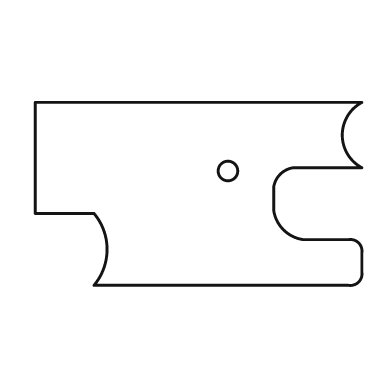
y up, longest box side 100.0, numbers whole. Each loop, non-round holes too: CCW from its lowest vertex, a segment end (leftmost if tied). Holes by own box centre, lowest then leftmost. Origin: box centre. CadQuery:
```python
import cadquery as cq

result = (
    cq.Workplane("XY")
    .moveTo(-32.0, -28.0)
    .lineTo(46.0, -28.0)
    .threePointArc((49.0, -27.0), (50.0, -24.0))
    .lineTo(50.0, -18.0)
    .threePointArc((49.0, -15.0), (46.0, -14.0))
    .lineTo(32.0, -14.0)
    .threePointArc((26.0, -11.0), (23.0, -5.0))
    .lineTo(23.0, 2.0)
    .threePointArc((25.0, 6.0), (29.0, 8.0))
    .lineTo(50.0, 8.0)
    .threePointArc((44.0, 18.0), (50.0, 28.0))
    .lineTo(-50.0, 28.0)
    .lineTo(-50.0, -6.0)
    .lineTo(-32.0, -6.0)
    .threePointArc((-28.0, -17.0), (-32.0, -28.0))
    .close()
    .moveTo(9.0, 7.0)
    .circle(3.0)
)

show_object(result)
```